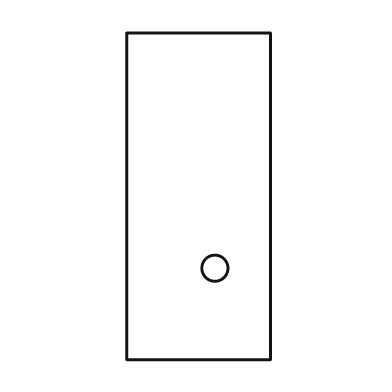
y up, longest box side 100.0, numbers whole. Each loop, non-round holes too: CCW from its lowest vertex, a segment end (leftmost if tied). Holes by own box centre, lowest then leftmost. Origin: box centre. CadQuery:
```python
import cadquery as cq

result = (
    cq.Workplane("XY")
    .moveTo(-22.0, -50.0)
    .lineTo(22.0, -50.0)
    .lineTo(22.0, 50.0)
    .lineTo(-22.0, 50.0)
    .close()
    .moveTo(5.0, -22.0)
    .circle(4.0)
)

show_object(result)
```